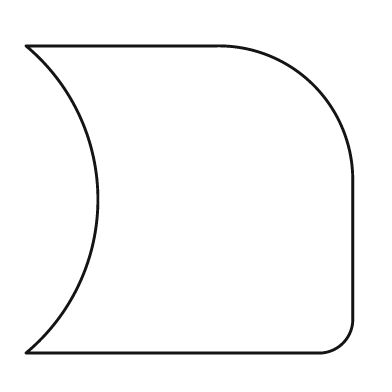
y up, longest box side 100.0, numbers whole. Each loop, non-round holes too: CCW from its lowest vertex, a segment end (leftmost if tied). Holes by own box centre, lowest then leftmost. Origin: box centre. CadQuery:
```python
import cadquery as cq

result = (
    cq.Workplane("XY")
    .moveTo(-50.0, -47.0)
    .lineTo(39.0, -47.0)
    .threePointArc((47.0, -44.0), (50.0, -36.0))
    .lineTo(50.0, 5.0)
    .threePointArc((38.0, 35.0), (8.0, 47.0))
    .lineTo(-50.0, 47.0)
    .threePointArc((-28.0, 0.0), (-50.0, -47.0))
    .close()
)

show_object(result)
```